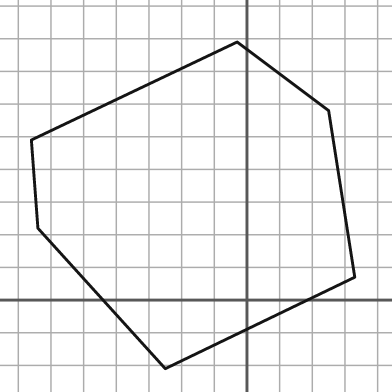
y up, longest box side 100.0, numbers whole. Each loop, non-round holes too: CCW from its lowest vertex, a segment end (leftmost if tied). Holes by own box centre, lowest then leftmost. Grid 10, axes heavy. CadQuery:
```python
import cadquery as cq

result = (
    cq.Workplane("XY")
    .moveTo(-25.0, -21.0)
    .lineTo(33.0, 7.0)
    .lineTo(25.0, 58.0)
    .lineTo(-3.0, 79.0)
    .lineTo(-66.0, 49.0)
    .lineTo(-64.0, 22.0)
    .close()
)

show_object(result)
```